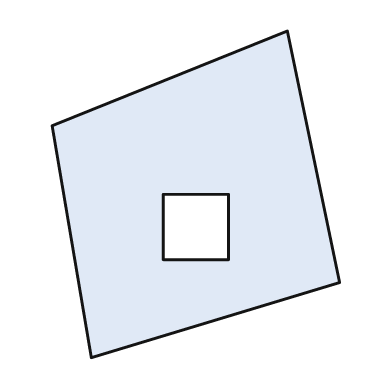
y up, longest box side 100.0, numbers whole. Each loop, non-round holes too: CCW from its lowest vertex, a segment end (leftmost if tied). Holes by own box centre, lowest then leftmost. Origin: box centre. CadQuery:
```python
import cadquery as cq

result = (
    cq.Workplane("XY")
    .moveTo(-32.0, -50.0)
    .lineTo(44.0, -27.0)
    .lineTo(28.0, 50.0)
    .lineTo(-44.0, 21.0)
    .close()
    .moveTo(-10.0, -20.0)
    .lineTo(10.0, -20.0)
    .lineTo(10.0, 0.0)
    .lineTo(-10.0, 0.0)
    .close()
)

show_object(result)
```